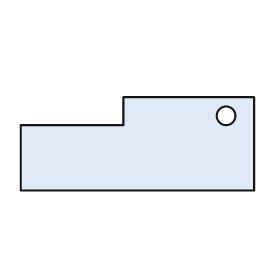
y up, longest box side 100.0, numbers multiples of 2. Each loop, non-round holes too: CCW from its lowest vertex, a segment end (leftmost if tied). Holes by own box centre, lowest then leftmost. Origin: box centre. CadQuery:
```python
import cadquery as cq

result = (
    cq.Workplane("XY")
    .moveTo(-50.0, -20.0)
    .lineTo(50.0, -20.0)
    .lineTo(50.0, 20.0)
    .lineTo(-6.0, 20.0)
    .lineTo(-6.0, 8.0)
    .lineTo(-50.0, 8.0)
    .close()
    .moveTo(38.0, 12.0)
    .circle(4.0)
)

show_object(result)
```